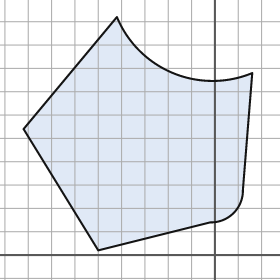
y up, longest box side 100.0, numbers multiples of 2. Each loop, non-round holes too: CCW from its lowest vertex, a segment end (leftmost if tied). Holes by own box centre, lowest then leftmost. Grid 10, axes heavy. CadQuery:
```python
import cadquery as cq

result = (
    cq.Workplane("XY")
    .moveTo(-50.0, 2.0)
    .lineTo(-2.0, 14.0)
    .threePointArc((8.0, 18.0), (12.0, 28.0))
    .lineTo(16.0, 78.0)
    .threePointArc((-18.0, 78.0), (-42.0, 102.0))
    .lineTo(-82.0, 54.0)
    .close()
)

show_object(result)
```